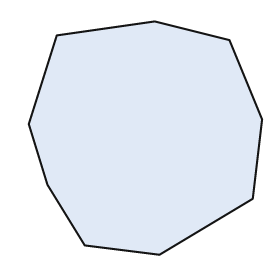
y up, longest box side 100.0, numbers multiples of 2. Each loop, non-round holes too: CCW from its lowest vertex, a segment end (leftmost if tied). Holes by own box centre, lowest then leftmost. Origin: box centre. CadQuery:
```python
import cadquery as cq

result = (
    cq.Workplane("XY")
    .moveTo(6.0, -50.0)
    .lineTo(46.0, -26.0)
    .lineTo(50.0, 8.0)
    .lineTo(36.0, 42.0)
    .lineTo(4.0, 50.0)
    .lineTo(-38.0, 44.0)
    .lineTo(-50.0, 6.0)
    .lineTo(-42.0, -20.0)
    .lineTo(-26.0, -46.0)
    .close()
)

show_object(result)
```